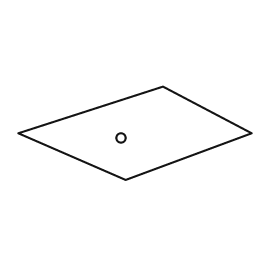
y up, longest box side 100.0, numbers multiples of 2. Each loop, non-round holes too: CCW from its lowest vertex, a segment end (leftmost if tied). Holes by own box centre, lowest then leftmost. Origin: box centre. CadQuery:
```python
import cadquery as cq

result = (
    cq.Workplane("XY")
    .moveTo(-4.0, -20.0)
    .lineTo(50.0, 0.0)
    .lineTo(12.0, 20.0)
    .lineTo(-50.0, 0.0)
    .close()
    .moveTo(-6.0, -2.0)
    .circle(2.0)
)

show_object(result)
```